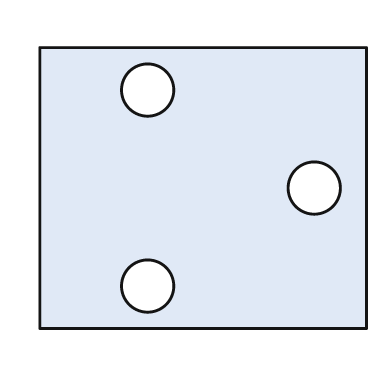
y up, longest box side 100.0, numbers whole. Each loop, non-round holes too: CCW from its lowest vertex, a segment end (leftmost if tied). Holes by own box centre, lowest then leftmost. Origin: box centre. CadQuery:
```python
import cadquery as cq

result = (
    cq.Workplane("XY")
    .moveTo(-50.0, -43.0)
    .lineTo(50.0, -43.0)
    .lineTo(50.0, 43.0)
    .lineTo(-50.0, 43.0)
    .close()
    .moveTo(-17.0, -30.0)
    .circle(8.0)
    .moveTo(34.0, 0.0)
    .circle(8.0)
    .moveTo(-17.0, 30.0)
    .circle(8.0)
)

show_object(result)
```